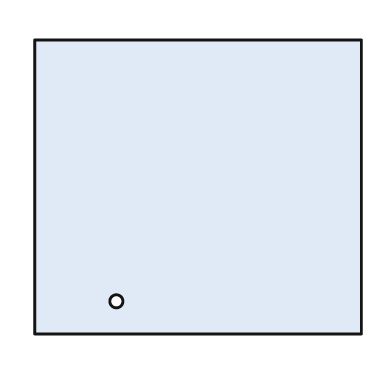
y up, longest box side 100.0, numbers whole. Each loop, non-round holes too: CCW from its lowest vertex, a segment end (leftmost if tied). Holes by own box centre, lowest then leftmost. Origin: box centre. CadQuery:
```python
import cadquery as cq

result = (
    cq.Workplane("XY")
    .moveTo(-50.0, -45.0)
    .lineTo(50.0, -45.0)
    .lineTo(50.0, 45.0)
    .lineTo(-50.0, 45.0)
    .close()
    .moveTo(-25.0, -35.0)
    .circle(2.0)
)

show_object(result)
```